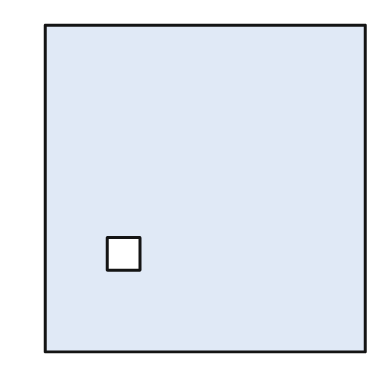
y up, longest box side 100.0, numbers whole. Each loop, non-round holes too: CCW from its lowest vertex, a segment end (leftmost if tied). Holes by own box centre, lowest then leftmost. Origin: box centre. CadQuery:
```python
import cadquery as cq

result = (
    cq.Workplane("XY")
    .moveTo(-49.0, -50.0)
    .lineTo(49.0, -50.0)
    .lineTo(49.0, 50.0)
    .lineTo(-49.0, 50.0)
    .close()
    .moveTo(-30.0, -25.0)
    .lineTo(-20.0, -25.0)
    .lineTo(-20.0, -15.0)
    .lineTo(-30.0, -15.0)
    .close()
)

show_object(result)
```